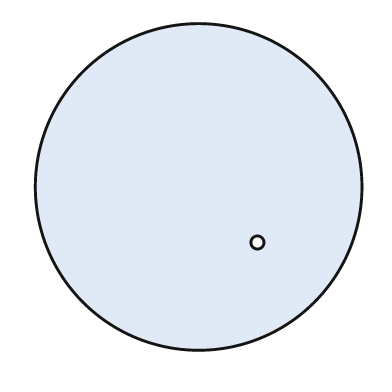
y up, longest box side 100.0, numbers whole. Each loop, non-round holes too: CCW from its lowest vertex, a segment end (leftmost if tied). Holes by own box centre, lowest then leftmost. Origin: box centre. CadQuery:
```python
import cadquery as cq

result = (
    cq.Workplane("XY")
    .moveTo(0.0, 0.0)
    .circle(50.0)
    .moveTo(18.0, -17.0)
    .circle(2.0)
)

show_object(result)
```